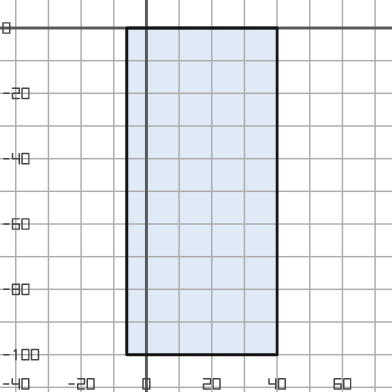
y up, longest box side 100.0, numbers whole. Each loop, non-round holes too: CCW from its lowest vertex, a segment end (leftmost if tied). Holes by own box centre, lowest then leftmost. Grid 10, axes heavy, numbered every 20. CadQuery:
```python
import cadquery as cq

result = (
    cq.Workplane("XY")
    .moveTo(-6.0, -100.0)
    .lineTo(40.0, -100.0)
    .lineTo(40.0, 0.0)
    .lineTo(-6.0, 0.0)
    .close()
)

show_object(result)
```